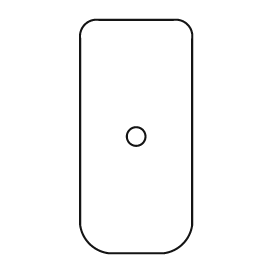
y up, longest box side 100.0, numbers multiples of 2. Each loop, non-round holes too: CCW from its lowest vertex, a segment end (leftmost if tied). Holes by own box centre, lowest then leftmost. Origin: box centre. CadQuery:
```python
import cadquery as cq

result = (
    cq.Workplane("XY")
    .moveTo(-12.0, -50.0)
    .lineTo(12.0, -50.0)
    .threePointArc((20.0, -46.0), (24.0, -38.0))
    .lineTo(24.0, 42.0)
    .threePointArc((22.0, 48.0), (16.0, 50.0))
    .lineTo(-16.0, 50.0)
    .threePointArc((-22.0, 48.0), (-24.0, 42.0))
    .lineTo(-24.0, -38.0)
    .threePointArc((-20.0, -46.0), (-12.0, -50.0))
    .close()
    .moveTo(0.0, 0.0)
    .circle(4.0)
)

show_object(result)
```